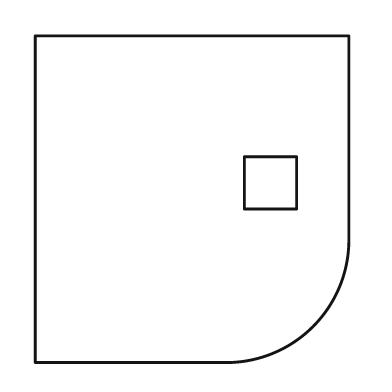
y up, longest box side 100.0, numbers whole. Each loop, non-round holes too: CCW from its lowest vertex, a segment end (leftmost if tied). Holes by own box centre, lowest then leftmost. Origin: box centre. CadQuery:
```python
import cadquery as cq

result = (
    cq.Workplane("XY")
    .moveTo(-48.0, -50.0)
    .lineTo(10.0, -50.0)
    .threePointArc((37.0, -39.0), (48.0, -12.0))
    .lineTo(48.0, 50.0)
    .lineTo(-48.0, 50.0)
    .close()
    .moveTo(16.0, -3.0)
    .lineTo(32.0, -3.0)
    .lineTo(32.0, 13.0)
    .lineTo(16.0, 13.0)
    .close()
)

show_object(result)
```